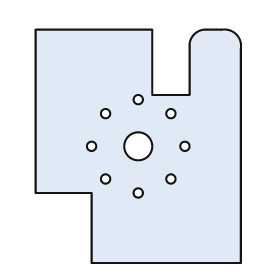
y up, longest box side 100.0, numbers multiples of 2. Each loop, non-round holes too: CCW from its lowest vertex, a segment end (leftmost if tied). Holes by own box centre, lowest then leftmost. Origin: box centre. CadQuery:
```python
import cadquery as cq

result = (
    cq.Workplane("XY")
    .moveTo(-20.0, -50.0)
    .lineTo(44.0, -50.0)
    .lineTo(44.0, 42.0)
    .threePointArc((42.0, 48.0), (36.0, 50.0))
    .lineTo(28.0, 50.0)
    .threePointArc((24.0, 48.0), (22.0, 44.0))
    .lineTo(22.0, 22.0)
    .lineTo(6.0, 22.0)
    .lineTo(6.0, 50.0)
    .lineTo(-44.0, 50.0)
    .lineTo(-44.0, -20.0)
    .lineTo(-20.0, -20.0)
    .close()
    .moveTo(0.0, -20.0)
    .circle(2.0)
    .moveTo(-14.0, -14.0)
    .circle(2.0)
    .moveTo(14.0, -14.0)
    .circle(2.0)
    .moveTo(-20.0, 0.0)
    .circle(2.0)
    .moveTo(0.0, 0.0)
    .circle(6.0)
    .moveTo(20.0, 0.0)
    .circle(2.0)
    .moveTo(-14.0, 14.0)
    .circle(2.0)
    .moveTo(14.0, 14.0)
    .circle(2.0)
    .moveTo(0.0, 20.0)
    .circle(2.0)
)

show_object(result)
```